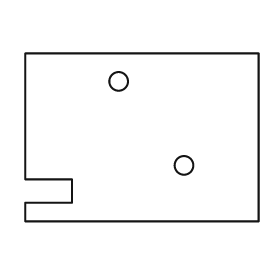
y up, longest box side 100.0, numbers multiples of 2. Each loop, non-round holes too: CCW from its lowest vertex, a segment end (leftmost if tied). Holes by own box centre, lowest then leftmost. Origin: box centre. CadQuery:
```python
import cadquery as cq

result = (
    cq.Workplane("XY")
    .moveTo(-50.0, -36.0)
    .lineTo(50.0, -36.0)
    .lineTo(50.0, 36.0)
    .lineTo(-50.0, 36.0)
    .lineTo(-50.0, -18.0)
    .lineTo(-30.0, -18.0)
    .lineTo(-30.0, -28.0)
    .lineTo(-50.0, -28.0)
    .close()
    .moveTo(18.0, -12.0)
    .circle(4.0)
    .moveTo(-10.0, 24.0)
    .circle(4.0)
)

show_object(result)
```